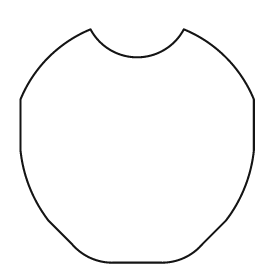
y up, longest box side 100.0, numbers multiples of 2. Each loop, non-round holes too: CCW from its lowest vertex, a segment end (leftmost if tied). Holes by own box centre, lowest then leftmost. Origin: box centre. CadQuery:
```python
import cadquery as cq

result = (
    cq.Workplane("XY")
    .moveTo(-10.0, -50.0)
    .lineTo(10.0, -50.0)
    .threePointArc((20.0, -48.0), (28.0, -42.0))
    .lineTo(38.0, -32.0)
    .threePointArc((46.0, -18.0), (50.0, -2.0))
    .lineTo(50.0, 20.0)
    .threePointArc((38.0, 38.0), (20.0, 50.0))
    .threePointArc((0.0, 38.0), (-20.0, 50.0))
    .threePointArc((-38.0, 38.0), (-50.0, 20.0))
    .lineTo(-50.0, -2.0)
    .threePointArc((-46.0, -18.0), (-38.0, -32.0))
    .lineTo(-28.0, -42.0)
    .threePointArc((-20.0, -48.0), (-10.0, -50.0))
    .close()
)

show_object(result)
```